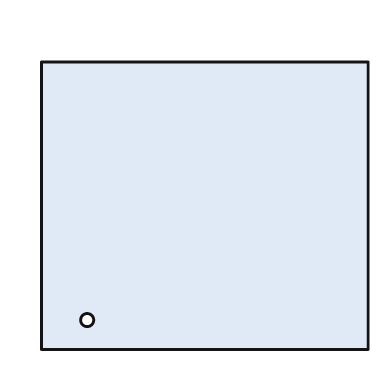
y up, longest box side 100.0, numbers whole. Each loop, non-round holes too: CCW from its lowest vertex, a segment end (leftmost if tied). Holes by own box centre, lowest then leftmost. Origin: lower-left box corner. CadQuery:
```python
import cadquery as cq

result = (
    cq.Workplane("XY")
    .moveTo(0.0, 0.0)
    .lineTo(100.0, 0.0)
    .lineTo(100.0, 88.0)
    .lineTo(0.0, 88.0)
    .close()
    .moveTo(14.0, 9.0)
    .circle(2.0)
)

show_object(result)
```